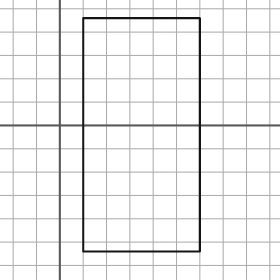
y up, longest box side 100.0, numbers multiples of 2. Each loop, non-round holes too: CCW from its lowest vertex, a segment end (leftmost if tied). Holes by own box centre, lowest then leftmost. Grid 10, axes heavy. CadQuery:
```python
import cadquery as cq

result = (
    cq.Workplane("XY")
    .moveTo(10.0, -54.0)
    .lineTo(60.0, -54.0)
    .lineTo(60.0, 46.0)
    .lineTo(10.0, 46.0)
    .close()
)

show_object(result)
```